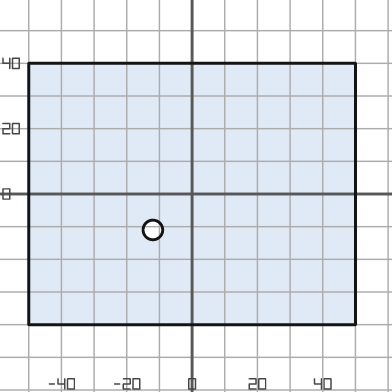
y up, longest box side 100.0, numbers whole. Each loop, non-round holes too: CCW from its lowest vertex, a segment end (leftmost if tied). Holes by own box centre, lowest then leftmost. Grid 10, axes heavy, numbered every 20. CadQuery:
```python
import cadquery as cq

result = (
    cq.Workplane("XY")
    .moveTo(-50.0, -40.0)
    .lineTo(50.0, -40.0)
    .lineTo(50.0, 40.0)
    .lineTo(-50.0, 40.0)
    .close()
    .moveTo(-12.0, -11.0)
    .circle(3.0)
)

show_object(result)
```